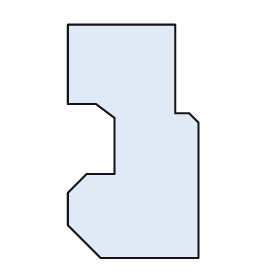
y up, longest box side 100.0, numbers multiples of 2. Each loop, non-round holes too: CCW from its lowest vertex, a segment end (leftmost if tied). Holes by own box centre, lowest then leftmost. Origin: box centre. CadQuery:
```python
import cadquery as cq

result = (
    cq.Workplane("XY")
    .moveTo(-14.0, -50.0)
    .lineTo(28.0, -50.0)
    .lineTo(28.0, 8.0)
    .lineTo(24.0, 12.0)
    .lineTo(18.0, 12.0)
    .lineTo(18.0, 50.0)
    .lineTo(-28.0, 50.0)
    .lineTo(-28.0, 16.0)
    .lineTo(-16.0, 16.0)
    .lineTo(-8.0, 10.0)
    .lineTo(-8.0, -14.0)
    .lineTo(-20.0, -14.0)
    .lineTo(-28.0, -22.0)
    .lineTo(-28.0, -36.0)
    .close()
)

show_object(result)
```